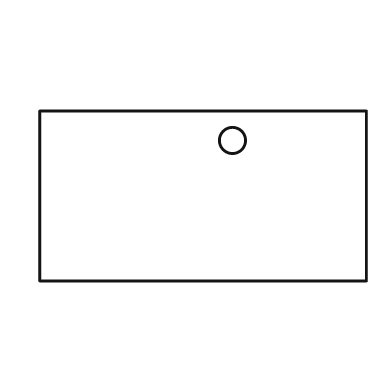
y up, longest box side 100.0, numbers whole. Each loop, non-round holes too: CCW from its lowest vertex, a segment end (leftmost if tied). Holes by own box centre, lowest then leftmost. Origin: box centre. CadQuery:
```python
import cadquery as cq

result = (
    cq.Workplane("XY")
    .moveTo(-50.0, -26.0)
    .lineTo(50.0, -26.0)
    .lineTo(50.0, 26.0)
    .lineTo(-50.0, 26.0)
    .close()
    .moveTo(9.0, 17.0)
    .circle(4.0)
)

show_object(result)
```